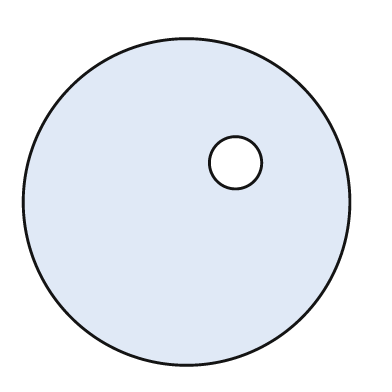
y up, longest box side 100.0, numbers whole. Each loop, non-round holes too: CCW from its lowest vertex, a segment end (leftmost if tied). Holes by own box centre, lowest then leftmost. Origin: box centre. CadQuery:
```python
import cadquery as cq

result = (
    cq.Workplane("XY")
    .moveTo(0.0, 0.0)
    .circle(50.0)
    .moveTo(15.0, 12.0)
    .circle(8.0)
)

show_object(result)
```